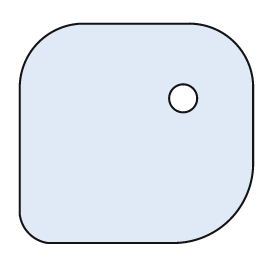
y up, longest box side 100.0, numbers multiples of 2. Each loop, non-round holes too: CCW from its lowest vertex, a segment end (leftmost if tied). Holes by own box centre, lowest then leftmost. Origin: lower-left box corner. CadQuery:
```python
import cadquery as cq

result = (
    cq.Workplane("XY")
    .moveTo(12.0, 0.0)
    .lineTo(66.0, 0.0)
    .threePointArc((90.0, 10.0), (100.0, 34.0))
    .lineTo(100.0, 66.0)
    .threePointArc((92.0, 86.0), (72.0, 94.0))
    .lineTo(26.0, 94.0)
    .threePointArc((8.0, 86.0), (0.0, 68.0))
    .lineTo(0.0, 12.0)
    .threePointArc((4.0, 4.0), (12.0, 0.0))
    .close()
    .moveTo(70.0, 62.0)
    .circle(6.0)
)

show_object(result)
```